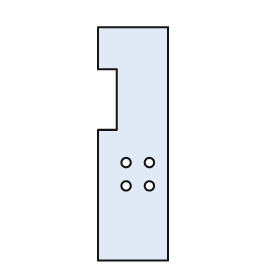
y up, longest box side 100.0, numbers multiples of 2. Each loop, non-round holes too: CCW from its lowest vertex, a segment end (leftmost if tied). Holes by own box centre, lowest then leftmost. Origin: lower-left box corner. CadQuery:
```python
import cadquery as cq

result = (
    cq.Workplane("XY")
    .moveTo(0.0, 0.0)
    .lineTo(30.0, 0.0)
    .lineTo(30.0, 100.0)
    .lineTo(0.0, 100.0)
    .lineTo(0.0, 82.0)
    .lineTo(8.0, 82.0)
    .lineTo(8.0, 56.0)
    .lineTo(0.0, 56.0)
    .close()
    .moveTo(12.0, 32.0)
    .circle(2.0)
    .moveTo(22.0, 32.0)
    .circle(2.0)
    .moveTo(12.0, 42.0)
    .circle(2.0)
    .moveTo(22.0, 42.0)
    .circle(2.0)
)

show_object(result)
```